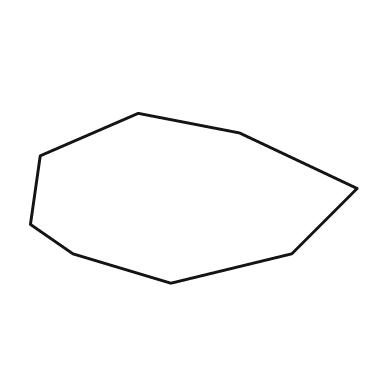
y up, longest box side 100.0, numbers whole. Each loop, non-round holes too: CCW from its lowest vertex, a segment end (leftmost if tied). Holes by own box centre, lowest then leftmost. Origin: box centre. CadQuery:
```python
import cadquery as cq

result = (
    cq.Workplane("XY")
    .moveTo(-7.0, -26.0)
    .lineTo(30.0, -17.0)
    .lineTo(50.0, 3.0)
    .lineTo(14.0, 20.0)
    .lineTo(-17.0, 26.0)
    .lineTo(-47.0, 13.0)
    .lineTo(-50.0, -8.0)
    .lineTo(-37.0, -17.0)
    .close()
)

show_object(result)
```